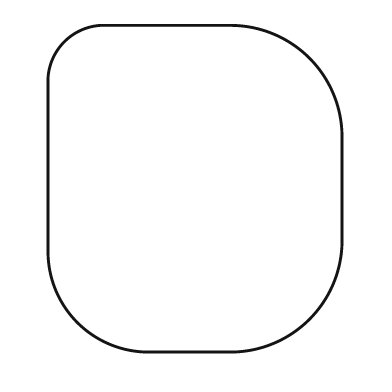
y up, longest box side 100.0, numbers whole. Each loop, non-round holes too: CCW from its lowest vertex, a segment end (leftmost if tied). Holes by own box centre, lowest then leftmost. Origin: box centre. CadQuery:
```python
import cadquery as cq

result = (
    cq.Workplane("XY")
    .moveTo(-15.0, -50.0)
    .lineTo(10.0, -50.0)
    .threePointArc((35.0, -40.0), (45.0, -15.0))
    .lineTo(45.0, 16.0)
    .threePointArc((35.0, 40.0), (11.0, 50.0))
    .lineTo(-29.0, 50.0)
    .threePointArc((-40.0, 45.0), (-45.0, 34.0))
    .lineTo(-45.0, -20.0)
    .threePointArc((-36.0, -41.0), (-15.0, -50.0))
    .close()
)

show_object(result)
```